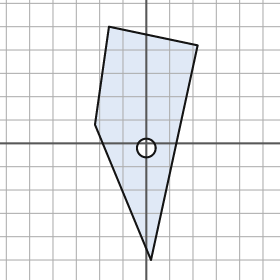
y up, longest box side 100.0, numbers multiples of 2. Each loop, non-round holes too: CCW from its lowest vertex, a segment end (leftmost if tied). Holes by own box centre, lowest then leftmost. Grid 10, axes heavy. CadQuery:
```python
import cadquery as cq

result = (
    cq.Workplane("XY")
    .moveTo(2.0, -50.0)
    .lineTo(22.0, 42.0)
    .lineTo(-16.0, 50.0)
    .lineTo(-22.0, 8.0)
    .close()
    .moveTo(0.0, -2.0)
    .circle(4.0)
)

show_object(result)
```